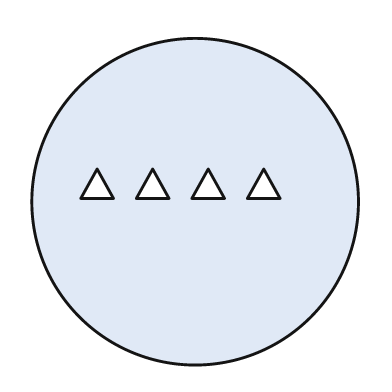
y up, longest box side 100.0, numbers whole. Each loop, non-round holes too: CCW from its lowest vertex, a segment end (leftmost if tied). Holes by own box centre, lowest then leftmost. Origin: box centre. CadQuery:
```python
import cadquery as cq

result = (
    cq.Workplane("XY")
    .moveTo(0.0, 0.0)
    .circle(50.0)
    .moveTo(-35.0, 1.0)
    .lineTo(-25.0, 1.0)
    .lineTo(-30.0, 10.0)
    .close()
    .moveTo(-18.0, 1.0)
    .lineTo(-8.0, 1.0)
    .lineTo(-13.0, 10.0)
    .close()
    .moveTo(-1.0, 1.0)
    .lineTo(9.0, 1.0)
    .lineTo(4.0, 10.0)
    .close()
    .moveTo(16.0, 1.0)
    .lineTo(26.0, 1.0)
    .lineTo(21.0, 10.0)
    .close()
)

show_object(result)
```